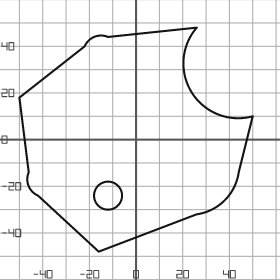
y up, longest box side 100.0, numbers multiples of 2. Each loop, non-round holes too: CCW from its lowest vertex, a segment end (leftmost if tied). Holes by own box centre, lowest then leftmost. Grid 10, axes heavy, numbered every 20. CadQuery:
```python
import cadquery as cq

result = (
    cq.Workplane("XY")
    .moveTo(-16.0, -48.0)
    .lineTo(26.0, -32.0)
    .threePointArc((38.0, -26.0), (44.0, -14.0))
    .lineTo(50.0, 10.0)
    .threePointArc((24.0, 20.0), (26.0, 48.0))
    .lineTo(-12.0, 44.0)
    .threePointArc((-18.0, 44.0), (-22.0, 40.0))
    .lineTo(-50.0, 18.0)
    .lineTo(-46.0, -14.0)
    .threePointArc((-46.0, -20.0), (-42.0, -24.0))
    .close()
    .moveTo(-12.0, -24.0)
    .circle(6.0)
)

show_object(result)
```